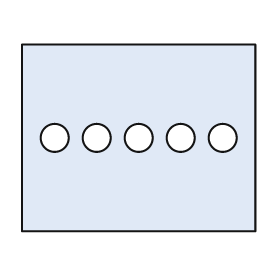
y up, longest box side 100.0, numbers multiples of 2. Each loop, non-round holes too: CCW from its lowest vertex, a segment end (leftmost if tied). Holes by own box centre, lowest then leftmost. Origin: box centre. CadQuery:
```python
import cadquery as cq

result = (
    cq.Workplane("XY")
    .moveTo(-50.0, -40.0)
    .lineTo(50.0, -40.0)
    .lineTo(50.0, 40.0)
    .lineTo(-50.0, 40.0)
    .close()
    .moveTo(-36.0, 0.0)
    .circle(6.0)
    .moveTo(-18.0, 0.0)
    .circle(6.0)
    .moveTo(0.0, 0.0)
    .circle(6.0)
    .moveTo(18.0, 0.0)
    .circle(6.0)
    .moveTo(36.0, 0.0)
    .circle(6.0)
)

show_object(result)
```